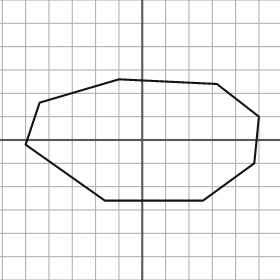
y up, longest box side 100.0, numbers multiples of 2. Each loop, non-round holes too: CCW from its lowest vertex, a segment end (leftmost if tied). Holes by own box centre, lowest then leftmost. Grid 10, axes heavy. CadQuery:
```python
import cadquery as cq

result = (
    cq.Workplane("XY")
    .moveTo(-16.0, -26.0)
    .lineTo(26.0, -26.0)
    .lineTo(48.0, -10.0)
    .lineTo(50.0, 10.0)
    .lineTo(32.0, 24.0)
    .lineTo(-10.0, 26.0)
    .lineTo(-44.0, 16.0)
    .lineTo(-50.0, -2.0)
    .close()
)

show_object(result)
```